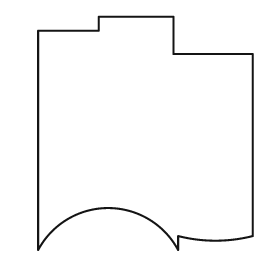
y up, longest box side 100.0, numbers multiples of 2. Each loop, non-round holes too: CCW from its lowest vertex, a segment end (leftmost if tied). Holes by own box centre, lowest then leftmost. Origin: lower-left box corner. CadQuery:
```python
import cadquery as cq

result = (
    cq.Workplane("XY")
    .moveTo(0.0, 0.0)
    .threePointArc((30.0, 18.0), (60.0, 0.0))
    .lineTo(60.0, 6.0)
    .threePointArc((76.0, 4.0), (92.0, 6.0))
    .lineTo(92.0, 84.0)
    .lineTo(58.0, 84.0)
    .lineTo(58.0, 100.0)
    .lineTo(26.0, 100.0)
    .lineTo(26.0, 94.0)
    .lineTo(0.0, 94.0)
    .close()
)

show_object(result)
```